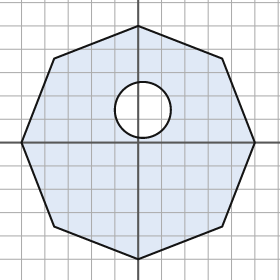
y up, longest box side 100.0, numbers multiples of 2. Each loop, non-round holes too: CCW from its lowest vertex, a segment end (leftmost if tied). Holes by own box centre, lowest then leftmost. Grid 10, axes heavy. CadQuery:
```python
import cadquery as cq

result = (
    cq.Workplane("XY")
    .moveTo(0.0, -50.0)
    .lineTo(36.0, -36.0)
    .lineTo(50.0, 0.0)
    .lineTo(36.0, 36.0)
    .lineTo(0.0, 50.0)
    .lineTo(-36.0, 36.0)
    .lineTo(-50.0, 0.0)
    .lineTo(-36.0, -36.0)
    .close()
    .moveTo(2.0, 14.0)
    .circle(12.0)
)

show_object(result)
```